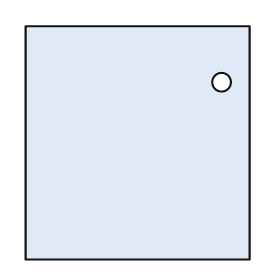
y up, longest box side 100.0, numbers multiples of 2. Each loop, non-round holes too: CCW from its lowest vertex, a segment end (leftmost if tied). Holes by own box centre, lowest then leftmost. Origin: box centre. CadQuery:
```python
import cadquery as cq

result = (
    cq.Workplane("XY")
    .moveTo(-48.0, -50.0)
    .lineTo(48.0, -50.0)
    .lineTo(48.0, 50.0)
    .lineTo(-48.0, 50.0)
    .close()
    .moveTo(36.0, 26.0)
    .circle(4.0)
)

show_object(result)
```